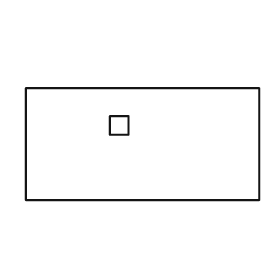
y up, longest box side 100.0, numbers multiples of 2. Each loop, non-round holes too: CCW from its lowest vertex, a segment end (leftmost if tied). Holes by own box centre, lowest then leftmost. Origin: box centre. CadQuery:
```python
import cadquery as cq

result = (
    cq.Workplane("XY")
    .moveTo(-50.0, -24.0)
    .lineTo(50.0, -24.0)
    .lineTo(50.0, 24.0)
    .lineTo(-50.0, 24.0)
    .close()
    .moveTo(-14.0, 4.0)
    .lineTo(-6.0, 4.0)
    .lineTo(-6.0, 12.0)
    .lineTo(-14.0, 12.0)
    .close()
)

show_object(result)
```